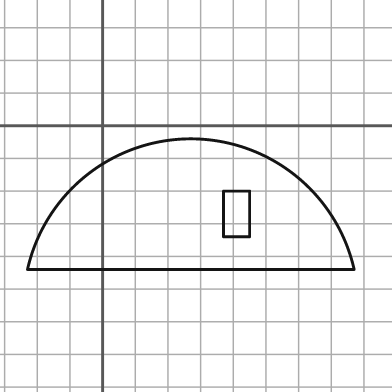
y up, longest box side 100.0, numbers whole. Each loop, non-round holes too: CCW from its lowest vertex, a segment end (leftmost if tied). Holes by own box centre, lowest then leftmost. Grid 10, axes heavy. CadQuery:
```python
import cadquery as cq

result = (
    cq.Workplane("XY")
    .moveTo(-23.0, -44.0)
    .lineTo(77.0, -44.0)
    .threePointArc((27.0, -4.0), (-23.0, -44.0))
    .close()
    .moveTo(37.0, -34.0)
    .lineTo(45.0, -34.0)
    .lineTo(45.0, -20.0)
    .lineTo(37.0, -20.0)
    .close()
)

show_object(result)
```